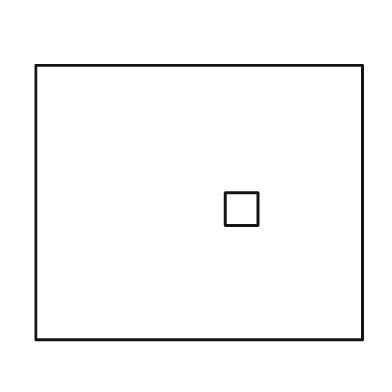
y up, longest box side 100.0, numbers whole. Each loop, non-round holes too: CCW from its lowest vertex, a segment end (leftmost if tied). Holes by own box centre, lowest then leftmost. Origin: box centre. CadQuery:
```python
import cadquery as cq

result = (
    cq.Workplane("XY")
    .moveTo(-50.0, -42.0)
    .lineTo(50.0, -42.0)
    .lineTo(50.0, 42.0)
    .lineTo(-50.0, 42.0)
    .close()
    .moveTo(8.0, -7.0)
    .lineTo(18.0, -7.0)
    .lineTo(18.0, 3.0)
    .lineTo(8.0, 3.0)
    .close()
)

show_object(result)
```